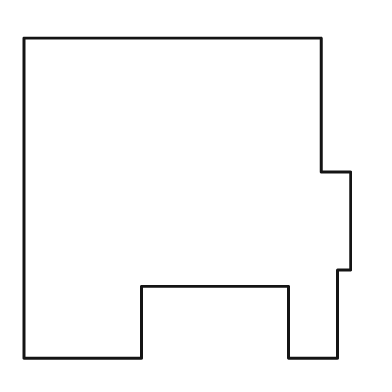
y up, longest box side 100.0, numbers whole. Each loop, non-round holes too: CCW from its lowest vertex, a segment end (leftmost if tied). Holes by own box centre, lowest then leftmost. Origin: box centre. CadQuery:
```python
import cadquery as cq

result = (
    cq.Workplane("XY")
    .moveTo(-50.0, -49.0)
    .lineTo(-14.0, -49.0)
    .lineTo(-14.0, -27.0)
    .lineTo(31.0, -27.0)
    .lineTo(31.0, -49.0)
    .lineTo(46.0, -49.0)
    .lineTo(46.0, -22.0)
    .lineTo(50.0, -22.0)
    .lineTo(50.0, 8.0)
    .lineTo(41.0, 8.0)
    .lineTo(41.0, 49.0)
    .lineTo(-50.0, 49.0)
    .close()
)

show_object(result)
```